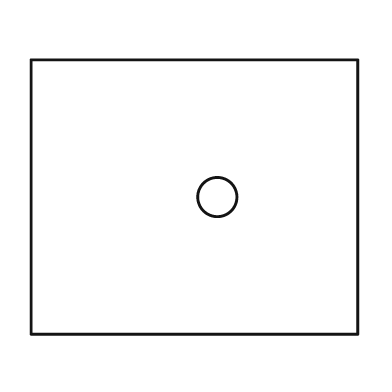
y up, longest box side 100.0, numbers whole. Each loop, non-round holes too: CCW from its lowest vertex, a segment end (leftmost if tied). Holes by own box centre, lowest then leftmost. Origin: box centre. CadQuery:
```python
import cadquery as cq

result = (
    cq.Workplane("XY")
    .moveTo(-50.0, -42.0)
    .lineTo(50.0, -42.0)
    .lineTo(50.0, 42.0)
    .lineTo(-50.0, 42.0)
    .close()
    .moveTo(7.0, 0.0)
    .circle(6.0)
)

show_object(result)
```